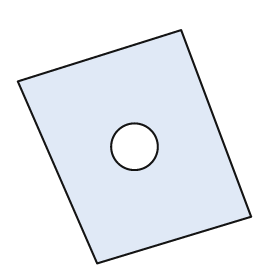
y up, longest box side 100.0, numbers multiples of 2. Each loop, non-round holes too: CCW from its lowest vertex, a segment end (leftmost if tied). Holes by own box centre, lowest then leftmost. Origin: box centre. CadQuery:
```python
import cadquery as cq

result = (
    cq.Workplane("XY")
    .moveTo(-16.0, -50.0)
    .lineTo(50.0, -30.0)
    .lineTo(20.0, 50.0)
    .lineTo(-50.0, 28.0)
    .close()
    .moveTo(0.0, 0.0)
    .circle(10.0)
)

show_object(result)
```